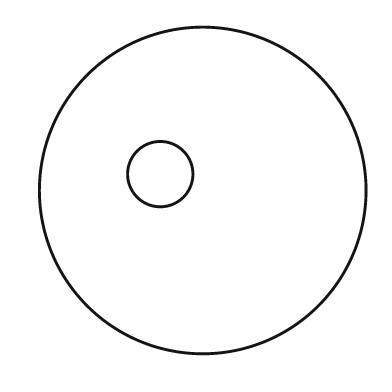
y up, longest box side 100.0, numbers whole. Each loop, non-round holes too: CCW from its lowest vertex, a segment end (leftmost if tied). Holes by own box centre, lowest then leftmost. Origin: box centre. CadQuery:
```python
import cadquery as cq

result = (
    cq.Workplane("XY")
    .moveTo(0.0, 0.0)
    .circle(50.0)
    .moveTo(-13.0, 5.0)
    .circle(10.0)
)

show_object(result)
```